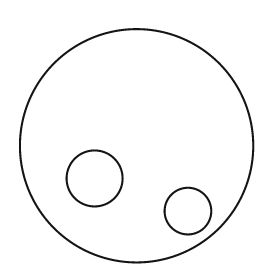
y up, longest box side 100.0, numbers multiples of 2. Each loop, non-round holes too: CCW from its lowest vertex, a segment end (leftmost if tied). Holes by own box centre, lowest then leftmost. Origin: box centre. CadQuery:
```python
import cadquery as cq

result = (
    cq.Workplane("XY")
    .moveTo(0.0, 0.0)
    .circle(50.0)
    .moveTo(22.0, -28.0)
    .circle(10.0)
    .moveTo(-18.0, -14.0)
    .circle(12.0)
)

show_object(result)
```